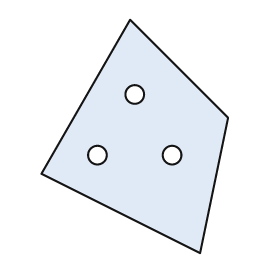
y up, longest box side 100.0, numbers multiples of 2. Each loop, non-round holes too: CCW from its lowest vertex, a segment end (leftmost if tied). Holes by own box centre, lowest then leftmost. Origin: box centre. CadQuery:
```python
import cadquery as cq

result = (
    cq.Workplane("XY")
    .moveTo(28.0, -50.0)
    .lineTo(40.0, 8.0)
    .lineTo(-2.0, 50.0)
    .lineTo(-40.0, -16.0)
    .close()
    .moveTo(-16.0, -8.0)
    .circle(4.0)
    .moveTo(16.0, -8.0)
    .circle(4.0)
    .moveTo(0.0, 18.0)
    .circle(4.0)
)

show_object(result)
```